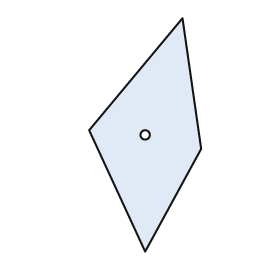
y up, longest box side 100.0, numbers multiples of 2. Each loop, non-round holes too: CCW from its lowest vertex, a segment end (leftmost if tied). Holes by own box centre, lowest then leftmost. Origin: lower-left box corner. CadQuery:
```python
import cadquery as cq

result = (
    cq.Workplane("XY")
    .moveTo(24.0, 0.0)
    .lineTo(48.0, 44.0)
    .lineTo(40.0, 100.0)
    .lineTo(0.0, 52.0)
    .close()
    .moveTo(24.0, 50.0)
    .circle(2.0)
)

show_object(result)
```